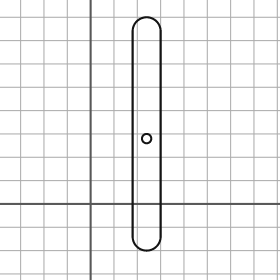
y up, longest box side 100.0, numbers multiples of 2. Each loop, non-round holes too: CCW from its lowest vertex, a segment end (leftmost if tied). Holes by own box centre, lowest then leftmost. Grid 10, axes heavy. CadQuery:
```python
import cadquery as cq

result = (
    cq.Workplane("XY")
    .moveTo(18.0, -14.0)
    .threePointArc((24.0, -20.0), (30.0, -14.0))
    .lineTo(30.0, 74.0)
    .threePointArc((24.0, 80.0), (18.0, 74.0))
    .close()
    .moveTo(24.0, 28.0)
    .circle(2.0)
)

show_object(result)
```